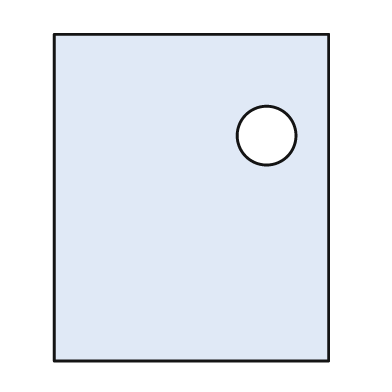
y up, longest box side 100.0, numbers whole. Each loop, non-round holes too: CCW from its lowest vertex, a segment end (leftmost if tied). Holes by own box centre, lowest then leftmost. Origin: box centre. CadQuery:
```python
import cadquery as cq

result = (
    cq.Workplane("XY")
    .moveTo(-42.0, -50.0)
    .lineTo(42.0, -50.0)
    .lineTo(42.0, 50.0)
    .lineTo(-42.0, 50.0)
    .close()
    .moveTo(23.0, 19.0)
    .circle(9.0)
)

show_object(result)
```